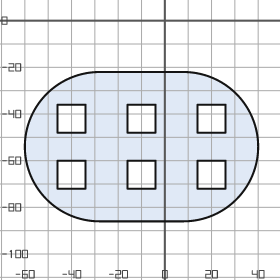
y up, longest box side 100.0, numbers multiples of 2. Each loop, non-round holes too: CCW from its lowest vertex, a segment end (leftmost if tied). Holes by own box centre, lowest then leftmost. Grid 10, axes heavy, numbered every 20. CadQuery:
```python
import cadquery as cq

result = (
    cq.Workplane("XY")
    .moveTo(-28.0, -86.0)
    .lineTo(8.0, -86.0)
    .threePointArc((40.0, -54.0), (8.0, -22.0))
    .lineTo(-28.0, -22.0)
    .threePointArc((-60.0, -54.0), (-28.0, -86.0))
    .close()
    .moveTo(-46.0, -72.0)
    .lineTo(-34.0, -72.0)
    .lineTo(-34.0, -60.0)
    .lineTo(-46.0, -60.0)
    .close()
    .moveTo(-16.0, -72.0)
    .lineTo(-4.0, -72.0)
    .lineTo(-4.0, -60.0)
    .lineTo(-16.0, -60.0)
    .close()
    .moveTo(14.0, -72.0)
    .lineTo(26.0, -72.0)
    .lineTo(26.0, -60.0)
    .lineTo(14.0, -60.0)
    .close()
    .moveTo(-46.0, -48.0)
    .lineTo(-34.0, -48.0)
    .lineTo(-34.0, -36.0)
    .lineTo(-46.0, -36.0)
    .close()
    .moveTo(-16.0, -48.0)
    .lineTo(-4.0, -48.0)
    .lineTo(-4.0, -36.0)
    .lineTo(-16.0, -36.0)
    .close()
    .moveTo(14.0, -48.0)
    .lineTo(26.0, -48.0)
    .lineTo(26.0, -36.0)
    .lineTo(14.0, -36.0)
    .close()
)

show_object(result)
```